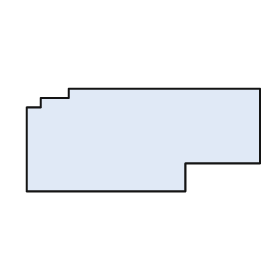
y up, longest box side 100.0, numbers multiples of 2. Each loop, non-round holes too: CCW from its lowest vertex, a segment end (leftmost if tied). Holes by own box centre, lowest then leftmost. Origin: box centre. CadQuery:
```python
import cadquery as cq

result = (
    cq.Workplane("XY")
    .moveTo(-50.0, -22.0)
    .lineTo(18.0, -22.0)
    .lineTo(18.0, -10.0)
    .lineTo(50.0, -10.0)
    .lineTo(50.0, 22.0)
    .lineTo(-32.0, 22.0)
    .lineTo(-32.0, 18.0)
    .lineTo(-44.0, 18.0)
    .lineTo(-44.0, 14.0)
    .lineTo(-50.0, 14.0)
    .close()
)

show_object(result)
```